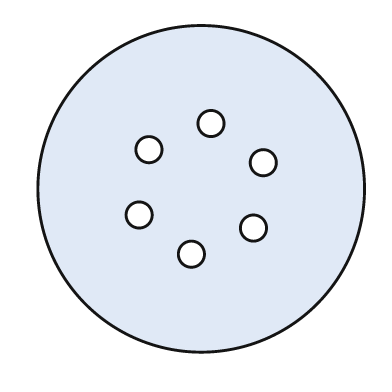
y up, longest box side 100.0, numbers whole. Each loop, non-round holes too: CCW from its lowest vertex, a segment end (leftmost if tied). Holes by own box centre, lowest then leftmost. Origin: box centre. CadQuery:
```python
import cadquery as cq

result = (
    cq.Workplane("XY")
    .moveTo(0.0, 0.0)
    .circle(50.0)
    .moveTo(-3.0, -20.0)
    .circle(4.0)
    .moveTo(16.0, -12.0)
    .circle(4.0)
    .moveTo(-19.0, -8.0)
    .circle(4.0)
    .moveTo(19.0, 8.0)
    .circle(4.0)
    .moveTo(-16.0, 12.0)
    .circle(4.0)
    .moveTo(3.0, 20.0)
    .circle(4.0)
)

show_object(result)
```